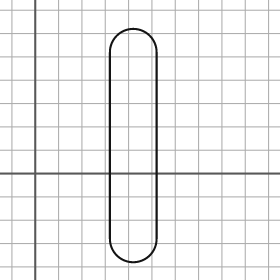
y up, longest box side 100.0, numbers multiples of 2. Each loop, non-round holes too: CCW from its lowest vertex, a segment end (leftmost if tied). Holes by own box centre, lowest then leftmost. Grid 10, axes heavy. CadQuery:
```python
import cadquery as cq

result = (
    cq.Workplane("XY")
    .moveTo(32.0, -28.0)
    .threePointArc((42.0, -38.0), (52.0, -28.0))
    .lineTo(52.0, 52.0)
    .threePointArc((42.0, 62.0), (32.0, 52.0))
    .close()
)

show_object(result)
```